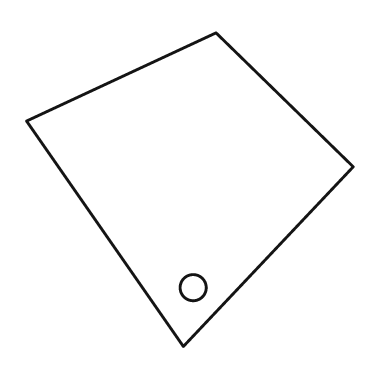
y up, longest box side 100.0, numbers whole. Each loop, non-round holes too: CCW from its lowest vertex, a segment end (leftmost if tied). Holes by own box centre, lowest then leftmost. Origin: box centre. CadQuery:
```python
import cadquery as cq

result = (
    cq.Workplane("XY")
    .moveTo(-2.0, -48.0)
    .lineTo(50.0, 7.0)
    .lineTo(8.0, 48.0)
    .lineTo(-50.0, 21.0)
    .close()
    .moveTo(1.0, -30.0)
    .circle(4.0)
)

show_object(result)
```